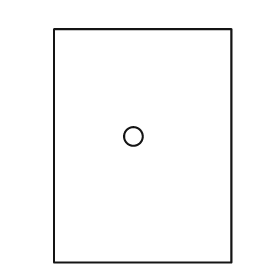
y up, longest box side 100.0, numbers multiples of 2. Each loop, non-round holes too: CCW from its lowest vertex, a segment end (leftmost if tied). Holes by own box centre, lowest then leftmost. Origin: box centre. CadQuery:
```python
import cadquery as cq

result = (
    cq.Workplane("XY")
    .moveTo(-38.0, -50.0)
    .lineTo(38.0, -50.0)
    .lineTo(38.0, 50.0)
    .lineTo(-38.0, 50.0)
    .close()
    .moveTo(-4.0, 4.0)
    .circle(4.0)
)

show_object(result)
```